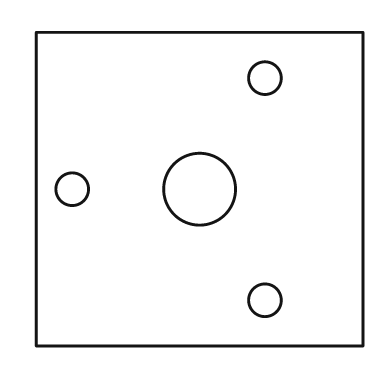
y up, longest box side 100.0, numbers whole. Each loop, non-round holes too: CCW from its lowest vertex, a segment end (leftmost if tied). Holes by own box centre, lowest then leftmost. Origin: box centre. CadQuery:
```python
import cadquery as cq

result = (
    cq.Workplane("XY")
    .moveTo(-50.0, -48.0)
    .lineTo(50.0, -48.0)
    .lineTo(50.0, 48.0)
    .lineTo(-50.0, 48.0)
    .close()
    .moveTo(20.0, -34.0)
    .circle(5.0)
    .moveTo(-39.0, 0.0)
    .circle(5.0)
    .moveTo(0.0, 0.0)
    .circle(11.0)
    .moveTo(20.0, 34.0)
    .circle(5.0)
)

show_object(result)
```